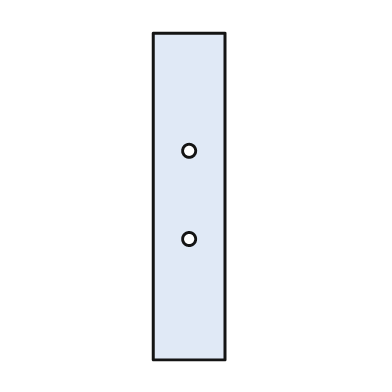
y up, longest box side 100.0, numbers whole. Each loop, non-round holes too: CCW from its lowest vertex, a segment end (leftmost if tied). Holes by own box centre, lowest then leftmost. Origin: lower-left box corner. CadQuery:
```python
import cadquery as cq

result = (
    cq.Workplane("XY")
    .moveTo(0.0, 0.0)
    .lineTo(22.0, 0.0)
    .lineTo(22.0, 100.0)
    .lineTo(0.0, 100.0)
    .close()
    .moveTo(11.0, 37.0)
    .circle(2.0)
    .moveTo(11.0, 64.0)
    .circle(2.0)
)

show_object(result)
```